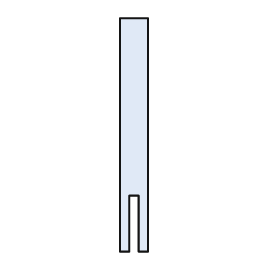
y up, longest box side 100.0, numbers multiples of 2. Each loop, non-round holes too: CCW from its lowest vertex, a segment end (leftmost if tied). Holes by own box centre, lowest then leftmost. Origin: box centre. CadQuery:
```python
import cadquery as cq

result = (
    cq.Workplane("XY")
    .moveTo(-6.0, -50.0)
    .lineTo(-2.0, -50.0)
    .lineTo(-2.0, -26.0)
    .lineTo(2.0, -26.0)
    .lineTo(2.0, -50.0)
    .lineTo(6.0, -50.0)
    .lineTo(6.0, 50.0)
    .lineTo(-6.0, 50.0)
    .close()
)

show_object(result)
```